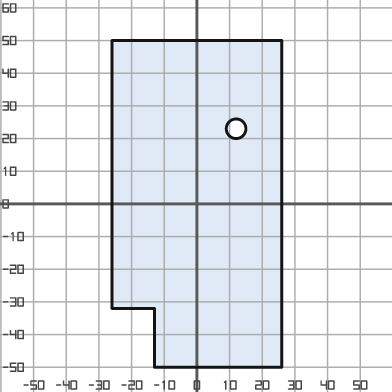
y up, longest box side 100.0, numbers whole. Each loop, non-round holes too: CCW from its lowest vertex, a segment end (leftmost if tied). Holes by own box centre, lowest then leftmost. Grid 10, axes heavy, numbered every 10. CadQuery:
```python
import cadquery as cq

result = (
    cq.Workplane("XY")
    .moveTo(-13.0, -50.0)
    .lineTo(26.0, -50.0)
    .lineTo(26.0, 50.0)
    .lineTo(-26.0, 50.0)
    .lineTo(-26.0, -32.0)
    .lineTo(-13.0, -32.0)
    .close()
    .moveTo(12.0, 23.0)
    .circle(3.0)
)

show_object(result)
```